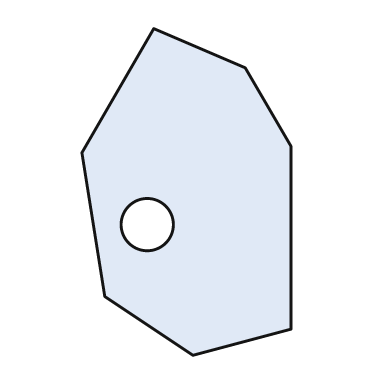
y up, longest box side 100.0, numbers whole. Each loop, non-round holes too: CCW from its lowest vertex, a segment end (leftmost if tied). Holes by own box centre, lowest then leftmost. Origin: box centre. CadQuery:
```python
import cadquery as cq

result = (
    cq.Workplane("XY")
    .moveTo(2.0, -50.0)
    .lineTo(32.0, -42.0)
    .lineTo(32.0, 14.0)
    .lineTo(18.0, 38.0)
    .lineTo(-10.0, 50.0)
    .lineTo(-32.0, 12.0)
    .lineTo(-25.0, -32.0)
    .close()
    .moveTo(-12.0, -10.0)
    .circle(8.0)
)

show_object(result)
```